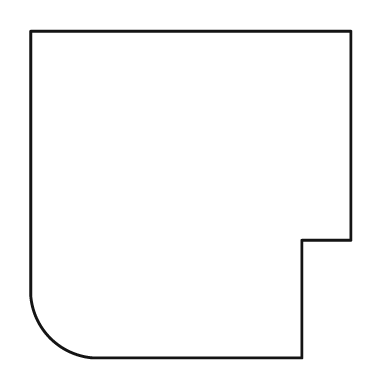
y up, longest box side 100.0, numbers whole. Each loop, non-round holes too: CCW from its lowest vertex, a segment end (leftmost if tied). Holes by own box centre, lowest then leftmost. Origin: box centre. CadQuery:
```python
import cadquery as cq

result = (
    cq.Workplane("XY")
    .moveTo(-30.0, -50.0)
    .lineTo(34.0, -50.0)
    .lineTo(34.0, -14.0)
    .lineTo(49.0, -14.0)
    .lineTo(49.0, 50.0)
    .lineTo(-49.0, 50.0)
    .lineTo(-49.0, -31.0)
    .threePointArc((-43.0, -44.0), (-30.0, -50.0))
    .close()
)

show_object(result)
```